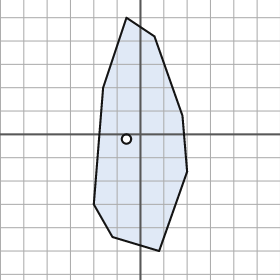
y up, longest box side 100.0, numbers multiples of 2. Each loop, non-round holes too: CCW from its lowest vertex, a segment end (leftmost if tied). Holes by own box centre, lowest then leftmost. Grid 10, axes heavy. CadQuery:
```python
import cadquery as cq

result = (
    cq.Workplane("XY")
    .moveTo(8.0, -50.0)
    .lineTo(20.0, -16.0)
    .lineTo(18.0, 8.0)
    .lineTo(6.0, 42.0)
    .lineTo(-6.0, 50.0)
    .lineTo(-16.0, 20.0)
    .lineTo(-20.0, -30.0)
    .lineTo(-12.0, -44.0)
    .close()
    .moveTo(-6.0, -2.0)
    .circle(2.0)
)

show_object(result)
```